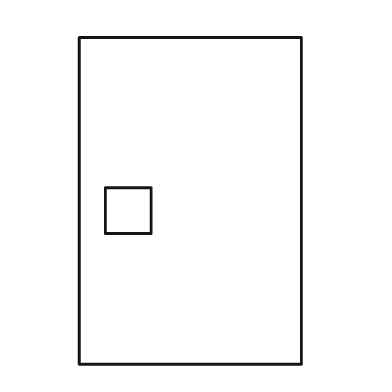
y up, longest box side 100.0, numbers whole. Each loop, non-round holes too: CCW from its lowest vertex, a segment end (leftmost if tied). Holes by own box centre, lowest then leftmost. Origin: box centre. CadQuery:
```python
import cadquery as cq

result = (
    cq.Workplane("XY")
    .moveTo(-34.0, -50.0)
    .lineTo(34.0, -50.0)
    .lineTo(34.0, 50.0)
    .lineTo(-34.0, 50.0)
    .close()
    .moveTo(-26.0, -10.0)
    .lineTo(-12.0, -10.0)
    .lineTo(-12.0, 4.0)
    .lineTo(-26.0, 4.0)
    .close()
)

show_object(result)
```